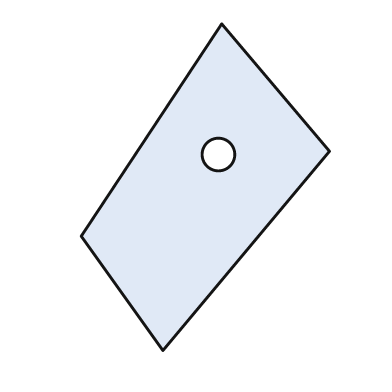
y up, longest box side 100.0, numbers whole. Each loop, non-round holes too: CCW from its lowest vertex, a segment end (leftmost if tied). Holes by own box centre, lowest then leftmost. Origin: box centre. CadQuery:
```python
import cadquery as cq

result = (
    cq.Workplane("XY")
    .moveTo(-13.0, -50.0)
    .lineTo(38.0, 11.0)
    .lineTo(5.0, 50.0)
    .lineTo(-38.0, -15.0)
    .close()
    .moveTo(4.0, 10.0)
    .circle(5.0)
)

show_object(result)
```